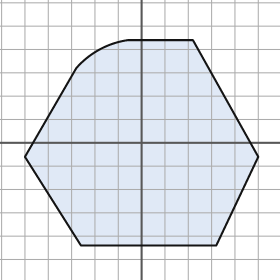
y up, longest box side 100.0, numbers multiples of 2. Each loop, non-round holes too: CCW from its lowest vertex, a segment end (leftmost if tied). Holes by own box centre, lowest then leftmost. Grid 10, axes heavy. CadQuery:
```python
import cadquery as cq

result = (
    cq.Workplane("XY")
    .moveTo(-26.0, -44.0)
    .lineTo(32.0, -44.0)
    .lineTo(50.0, -6.0)
    .lineTo(22.0, 44.0)
    .lineTo(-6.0, 44.0)
    .threePointArc((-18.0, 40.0), (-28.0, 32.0))
    .lineTo(-50.0, -6.0)
    .close()
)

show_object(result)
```